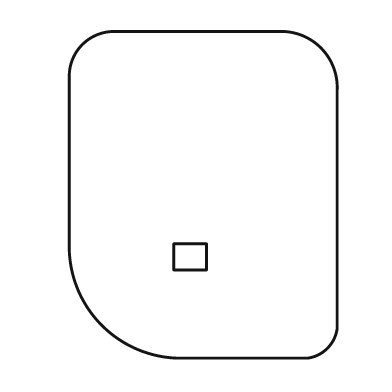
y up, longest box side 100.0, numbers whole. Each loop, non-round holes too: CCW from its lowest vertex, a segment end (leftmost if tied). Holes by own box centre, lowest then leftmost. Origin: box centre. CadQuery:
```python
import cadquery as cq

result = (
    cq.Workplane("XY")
    .moveTo(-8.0, -50.0)
    .lineTo(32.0, -50.0)
    .threePointArc((38.0, -47.0), (41.0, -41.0))
    .lineTo(41.0, 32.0)
    .threePointArc((36.0, 45.0), (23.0, 50.0))
    .lineTo(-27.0, 50.0)
    .threePointArc((-37.0, 46.0), (-41.0, 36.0))
    .lineTo(-41.0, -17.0)
    .threePointArc((-31.0, -40.0), (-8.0, -50.0))
    .close()
    .moveTo(-9.0, -23.0)
    .lineTo(1.0, -23.0)
    .lineTo(1.0, -15.0)
    .lineTo(-9.0, -15.0)
    .close()
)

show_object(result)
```